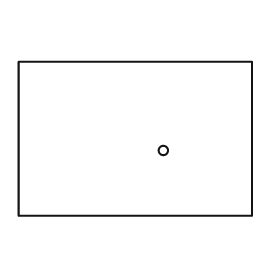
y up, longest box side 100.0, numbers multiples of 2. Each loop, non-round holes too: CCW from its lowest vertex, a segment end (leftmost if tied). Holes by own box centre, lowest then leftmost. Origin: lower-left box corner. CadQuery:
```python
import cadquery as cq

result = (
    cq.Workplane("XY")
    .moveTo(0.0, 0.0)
    .lineTo(100.0, 0.0)
    .lineTo(100.0, 66.0)
    .lineTo(0.0, 66.0)
    .close()
    .moveTo(62.0, 28.0)
    .circle(2.0)
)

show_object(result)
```